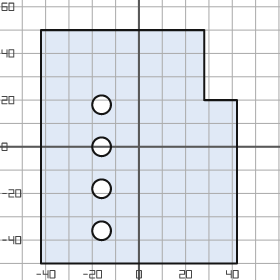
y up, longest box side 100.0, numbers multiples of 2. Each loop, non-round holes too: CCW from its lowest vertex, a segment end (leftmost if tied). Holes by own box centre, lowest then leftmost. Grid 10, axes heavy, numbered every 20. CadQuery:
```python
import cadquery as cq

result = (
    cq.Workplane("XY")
    .moveTo(-42.0, -50.0)
    .lineTo(42.0, -50.0)
    .lineTo(42.0, 20.0)
    .lineTo(28.0, 20.0)
    .lineTo(28.0, 50.0)
    .lineTo(-42.0, 50.0)
    .close()
    .moveTo(-16.0, -36.0)
    .circle(4.0)
    .moveTo(-16.0, -18.0)
    .circle(4.0)
    .moveTo(-16.0, 0.0)
    .circle(4.0)
    .moveTo(-16.0, 18.0)
    .circle(4.0)
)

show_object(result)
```